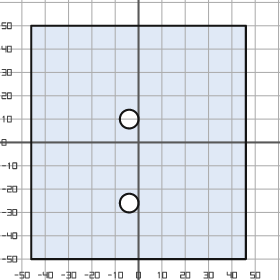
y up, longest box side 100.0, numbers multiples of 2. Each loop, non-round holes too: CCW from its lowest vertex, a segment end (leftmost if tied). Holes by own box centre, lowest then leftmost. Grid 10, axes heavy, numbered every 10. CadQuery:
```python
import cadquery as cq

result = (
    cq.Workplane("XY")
    .moveTo(-46.0, -50.0)
    .lineTo(46.0, -50.0)
    .lineTo(46.0, 50.0)
    .lineTo(-46.0, 50.0)
    .close()
    .moveTo(-4.0, -26.0)
    .circle(4.0)
    .moveTo(-4.0, 10.0)
    .circle(4.0)
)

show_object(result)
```